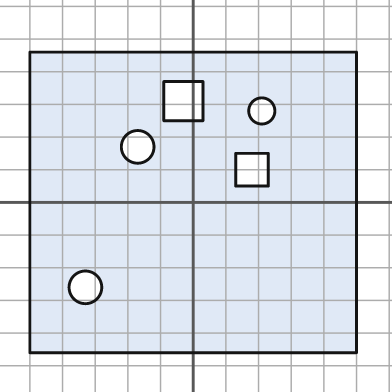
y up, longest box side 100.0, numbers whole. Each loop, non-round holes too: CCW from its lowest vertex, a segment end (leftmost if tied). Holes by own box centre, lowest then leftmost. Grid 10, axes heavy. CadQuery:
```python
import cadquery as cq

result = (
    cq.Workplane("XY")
    .moveTo(-50.0, -46.0)
    .lineTo(50.0, -46.0)
    .lineTo(50.0, 46.0)
    .lineTo(-50.0, 46.0)
    .close()
    .moveTo(-33.0, -26.0)
    .circle(5.0)
    .moveTo(13.0, 5.0)
    .lineTo(23.0, 5.0)
    .lineTo(23.0, 15.0)
    .lineTo(13.0, 15.0)
    .close()
    .moveTo(-17.0, 17.0)
    .circle(5.0)
    .moveTo(21.0, 28.0)
    .circle(4.0)
    .moveTo(-9.0, 25.0)
    .lineTo(3.0, 25.0)
    .lineTo(3.0, 37.0)
    .lineTo(-9.0, 37.0)
    .close()
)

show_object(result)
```